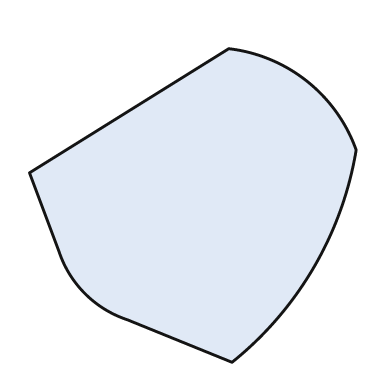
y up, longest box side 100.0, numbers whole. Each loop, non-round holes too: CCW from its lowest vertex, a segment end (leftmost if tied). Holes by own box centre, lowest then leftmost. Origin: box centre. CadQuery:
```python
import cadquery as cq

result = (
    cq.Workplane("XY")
    .moveTo(12.0, -48.0)
    .threePointArc((37.0, -19.0), (50.0, 17.0))
    .threePointArc((35.0, 38.0), (11.0, 48.0))
    .lineTo(-50.0, 10.0)
    .lineTo(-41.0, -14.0)
    .threePointArc((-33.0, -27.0), (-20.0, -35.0))
    .close()
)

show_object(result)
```